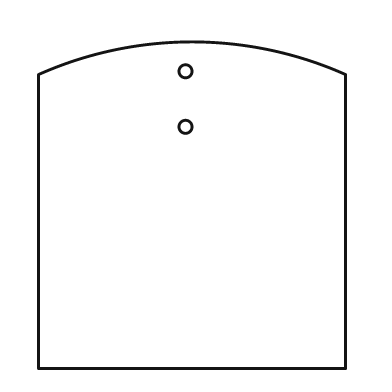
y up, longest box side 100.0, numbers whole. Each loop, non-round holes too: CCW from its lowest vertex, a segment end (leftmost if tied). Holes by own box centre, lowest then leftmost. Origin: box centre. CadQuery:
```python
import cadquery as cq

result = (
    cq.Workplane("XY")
    .moveTo(-47.0, -50.0)
    .lineTo(47.0, -50.0)
    .lineTo(47.0, 40.0)
    .threePointArc((0.0, 50.0), (-47.0, 40.0))
    .close()
    .moveTo(-2.0, 24.0)
    .circle(2.0)
    .moveTo(-2.0, 41.0)
    .circle(2.0)
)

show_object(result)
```